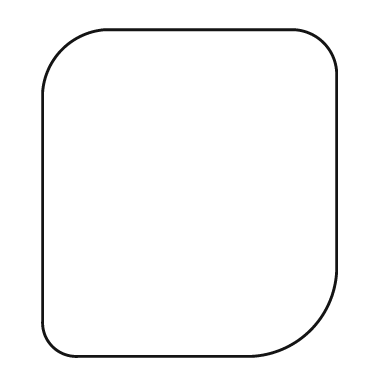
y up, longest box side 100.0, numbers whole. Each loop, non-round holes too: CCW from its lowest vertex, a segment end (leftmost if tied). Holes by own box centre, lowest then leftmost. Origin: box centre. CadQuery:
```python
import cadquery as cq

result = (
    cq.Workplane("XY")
    .moveTo(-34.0, -50.0)
    .lineTo(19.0, -50.0)
    .threePointArc((37.0, -42.0), (45.0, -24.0))
    .lineTo(45.0, 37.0)
    .threePointArc((41.0, 46.0), (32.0, 50.0))
    .lineTo(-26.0, 50.0)
    .threePointArc((-39.0, 44.0), (-45.0, 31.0))
    .lineTo(-45.0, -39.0)
    .threePointArc((-42.0, -47.0), (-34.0, -50.0))
    .close()
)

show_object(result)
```